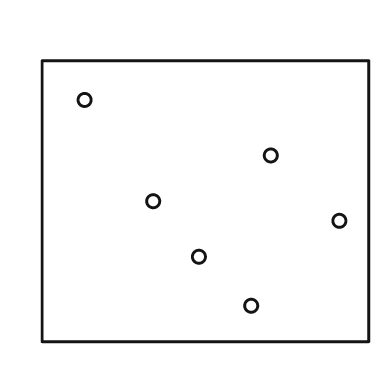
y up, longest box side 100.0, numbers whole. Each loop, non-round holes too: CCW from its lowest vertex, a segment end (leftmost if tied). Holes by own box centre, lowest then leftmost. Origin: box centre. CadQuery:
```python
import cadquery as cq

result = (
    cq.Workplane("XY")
    .moveTo(-50.0, -43.0)
    .lineTo(50.0, -43.0)
    .lineTo(50.0, 43.0)
    .lineTo(-50.0, 43.0)
    .close()
    .moveTo(14.0, -32.0)
    .circle(2.0)
    .moveTo(-2.0, -17.0)
    .circle(2.0)
    .moveTo(41.0, -6.0)
    .circle(2.0)
    .moveTo(-16.0, 0.0)
    .circle(2.0)
    .moveTo(20.0, 14.0)
    .circle(2.0)
    .moveTo(-37.0, 31.0)
    .circle(2.0)
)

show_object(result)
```